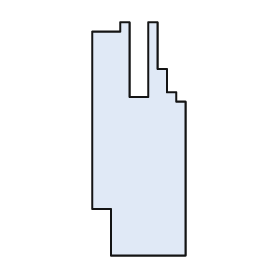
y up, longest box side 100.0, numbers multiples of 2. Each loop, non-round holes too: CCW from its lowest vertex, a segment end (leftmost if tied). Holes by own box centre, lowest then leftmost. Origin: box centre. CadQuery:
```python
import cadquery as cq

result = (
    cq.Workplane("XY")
    .moveTo(-12.0, -50.0)
    .lineTo(20.0, -50.0)
    .lineTo(20.0, 16.0)
    .lineTo(16.0, 16.0)
    .lineTo(16.0, 20.0)
    .lineTo(12.0, 20.0)
    .lineTo(12.0, 30.0)
    .lineTo(8.0, 30.0)
    .lineTo(8.0, 50.0)
    .lineTo(4.0, 50.0)
    .lineTo(4.0, 18.0)
    .lineTo(-4.0, 18.0)
    .lineTo(-4.0, 50.0)
    .lineTo(-8.0, 50.0)
    .lineTo(-8.0, 46.0)
    .lineTo(-20.0, 46.0)
    .lineTo(-20.0, -30.0)
    .lineTo(-12.0, -30.0)
    .close()
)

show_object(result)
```